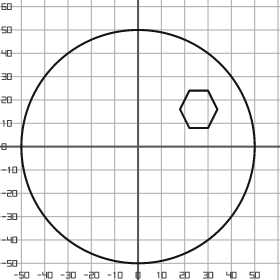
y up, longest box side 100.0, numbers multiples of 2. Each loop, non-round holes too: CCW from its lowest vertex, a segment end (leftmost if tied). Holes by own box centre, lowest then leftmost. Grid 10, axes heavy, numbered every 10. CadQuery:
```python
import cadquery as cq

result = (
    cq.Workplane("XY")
    .moveTo(0.0, 0.0)
    .circle(50.0)
    .moveTo(22.0, 8.0)
    .lineTo(30.0, 8.0)
    .lineTo(34.0, 16.0)
    .lineTo(30.0, 24.0)
    .lineTo(22.0, 24.0)
    .lineTo(18.0, 16.0)
    .close()
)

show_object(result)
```